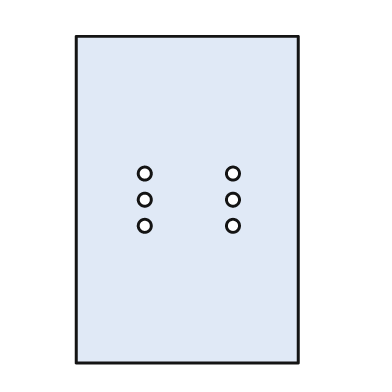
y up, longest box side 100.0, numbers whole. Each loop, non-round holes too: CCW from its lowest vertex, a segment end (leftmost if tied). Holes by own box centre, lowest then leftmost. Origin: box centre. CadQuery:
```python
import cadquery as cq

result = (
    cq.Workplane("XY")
    .moveTo(-34.0, -50.0)
    .lineTo(34.0, -50.0)
    .lineTo(34.0, 50.0)
    .lineTo(-34.0, 50.0)
    .close()
    .moveTo(-13.0, -8.0)
    .circle(2.0)
    .moveTo(14.0, -8.0)
    .circle(2.0)
    .moveTo(-13.0, 0.0)
    .circle(2.0)
    .moveTo(14.0, 0.0)
    .circle(2.0)
    .moveTo(-13.0, 8.0)
    .circle(2.0)
    .moveTo(14.0, 8.0)
    .circle(2.0)
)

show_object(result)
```